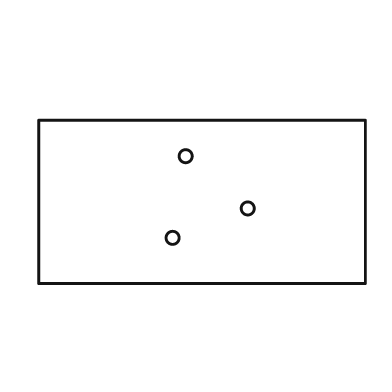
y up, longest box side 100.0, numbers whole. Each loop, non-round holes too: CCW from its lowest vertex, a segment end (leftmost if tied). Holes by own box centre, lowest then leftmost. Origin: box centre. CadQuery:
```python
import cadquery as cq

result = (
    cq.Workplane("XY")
    .moveTo(-50.0, -25.0)
    .lineTo(50.0, -25.0)
    .lineTo(50.0, 25.0)
    .lineTo(-50.0, 25.0)
    .close()
    .moveTo(-9.0, -11.0)
    .circle(2.0)
    .moveTo(14.0, -2.0)
    .circle(2.0)
    .moveTo(-5.0, 14.0)
    .circle(2.0)
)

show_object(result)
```